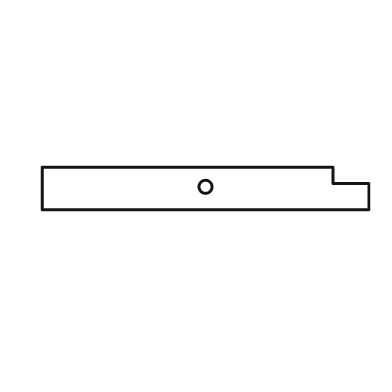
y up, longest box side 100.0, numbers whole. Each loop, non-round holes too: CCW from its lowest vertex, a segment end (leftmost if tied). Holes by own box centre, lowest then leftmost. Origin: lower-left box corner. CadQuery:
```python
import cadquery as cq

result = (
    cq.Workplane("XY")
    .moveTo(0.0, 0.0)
    .lineTo(100.0, 0.0)
    .lineTo(100.0, 8.0)
    .lineTo(89.0, 8.0)
    .lineTo(89.0, 13.0)
    .lineTo(0.0, 13.0)
    .close()
    .moveTo(50.0, 7.0)
    .circle(2.0)
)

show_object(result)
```